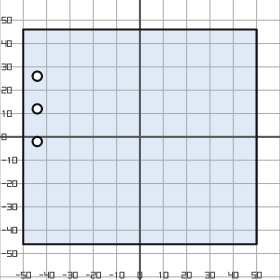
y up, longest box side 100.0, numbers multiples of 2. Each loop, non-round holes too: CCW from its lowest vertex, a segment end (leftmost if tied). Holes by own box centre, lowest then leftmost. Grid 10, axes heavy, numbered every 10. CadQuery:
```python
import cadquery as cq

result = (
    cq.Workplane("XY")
    .moveTo(-50.0, -46.0)
    .lineTo(50.0, -46.0)
    .lineTo(50.0, 46.0)
    .lineTo(-50.0, 46.0)
    .close()
    .moveTo(-44.0, -2.0)
    .circle(2.0)
    .moveTo(-44.0, 12.0)
    .circle(2.0)
    .moveTo(-44.0, 26.0)
    .circle(2.0)
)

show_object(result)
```